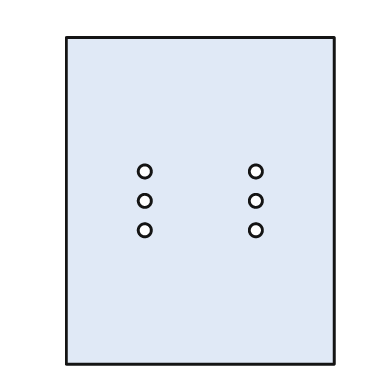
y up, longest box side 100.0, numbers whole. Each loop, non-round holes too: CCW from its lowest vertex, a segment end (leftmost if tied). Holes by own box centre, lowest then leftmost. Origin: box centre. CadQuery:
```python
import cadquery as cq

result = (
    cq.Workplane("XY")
    .moveTo(-41.0, -50.0)
    .lineTo(41.0, -50.0)
    .lineTo(41.0, 50.0)
    .lineTo(-41.0, 50.0)
    .close()
    .moveTo(-17.0, -9.0)
    .circle(2.0)
    .moveTo(17.0, -9.0)
    .circle(2.0)
    .moveTo(-17.0, 0.0)
    .circle(2.0)
    .moveTo(17.0, 0.0)
    .circle(2.0)
    .moveTo(-17.0, 9.0)
    .circle(2.0)
    .moveTo(17.0, 9.0)
    .circle(2.0)
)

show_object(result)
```